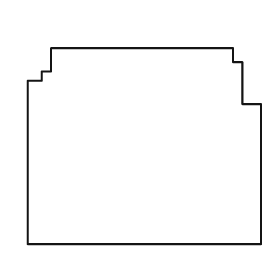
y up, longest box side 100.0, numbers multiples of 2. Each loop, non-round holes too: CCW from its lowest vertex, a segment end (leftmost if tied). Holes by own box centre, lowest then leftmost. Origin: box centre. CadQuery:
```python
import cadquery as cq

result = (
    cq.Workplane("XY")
    .moveTo(-50.0, -42.0)
    .lineTo(50.0, -42.0)
    .lineTo(50.0, 18.0)
    .lineTo(42.0, 18.0)
    .lineTo(42.0, 36.0)
    .lineTo(38.0, 36.0)
    .lineTo(38.0, 42.0)
    .lineTo(-40.0, 42.0)
    .lineTo(-40.0, 32.0)
    .lineTo(-44.0, 32.0)
    .lineTo(-44.0, 28.0)
    .lineTo(-50.0, 28.0)
    .close()
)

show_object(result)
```